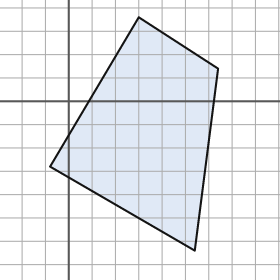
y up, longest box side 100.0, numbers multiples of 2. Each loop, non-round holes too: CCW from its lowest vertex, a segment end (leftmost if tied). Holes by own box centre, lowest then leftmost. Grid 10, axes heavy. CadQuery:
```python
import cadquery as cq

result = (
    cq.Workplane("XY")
    .moveTo(54.0, -64.0)
    .lineTo(64.0, 14.0)
    .lineTo(30.0, 36.0)
    .lineTo(-8.0, -28.0)
    .close()
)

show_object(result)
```